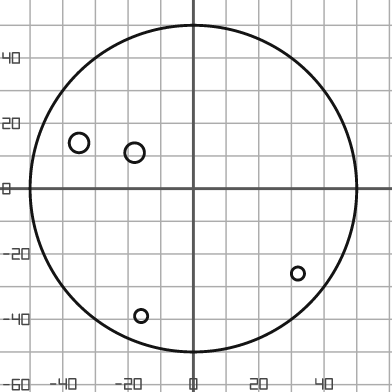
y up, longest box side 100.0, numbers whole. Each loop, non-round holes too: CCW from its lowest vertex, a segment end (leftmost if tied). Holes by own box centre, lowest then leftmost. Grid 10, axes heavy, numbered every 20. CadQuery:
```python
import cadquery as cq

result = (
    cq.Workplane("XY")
    .moveTo(0.0, 0.0)
    .circle(50.0)
    .moveTo(-16.0, -39.0)
    .circle(2.0)
    .moveTo(32.0, -26.0)
    .circle(2.0)
    .moveTo(-18.0, 11.0)
    .circle(3.0)
    .moveTo(-35.0, 14.0)
    .circle(3.0)
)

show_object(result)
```